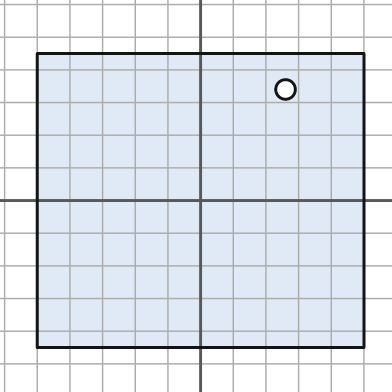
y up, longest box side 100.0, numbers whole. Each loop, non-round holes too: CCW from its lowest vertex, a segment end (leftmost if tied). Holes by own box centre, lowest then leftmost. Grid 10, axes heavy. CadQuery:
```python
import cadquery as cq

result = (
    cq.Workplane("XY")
    .moveTo(-50.0, -45.0)
    .lineTo(50.0, -45.0)
    .lineTo(50.0, 45.0)
    .lineTo(-50.0, 45.0)
    .close()
    .moveTo(26.0, 34.0)
    .circle(3.0)
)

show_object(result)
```